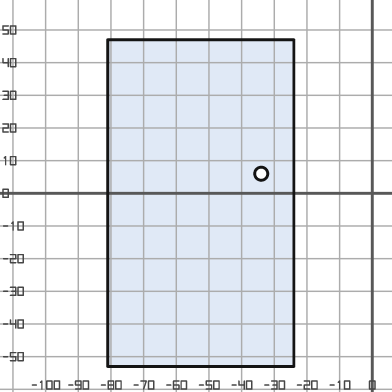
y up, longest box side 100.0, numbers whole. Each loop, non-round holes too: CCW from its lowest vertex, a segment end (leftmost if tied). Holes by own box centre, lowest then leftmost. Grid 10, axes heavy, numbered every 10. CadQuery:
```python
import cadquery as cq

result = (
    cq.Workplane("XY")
    .moveTo(-81.0, -53.0)
    .lineTo(-24.0, -53.0)
    .lineTo(-24.0, 47.0)
    .lineTo(-81.0, 47.0)
    .close()
    .moveTo(-34.0, 6.0)
    .circle(2.0)
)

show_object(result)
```